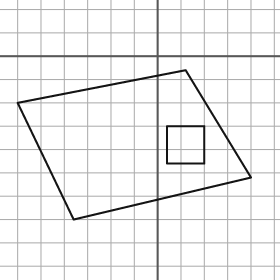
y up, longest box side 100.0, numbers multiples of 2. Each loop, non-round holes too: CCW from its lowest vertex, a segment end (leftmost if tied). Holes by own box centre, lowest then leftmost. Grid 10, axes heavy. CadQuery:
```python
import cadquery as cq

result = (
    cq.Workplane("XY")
    .moveTo(-36.0, -70.0)
    .lineTo(40.0, -52.0)
    .lineTo(12.0, -6.0)
    .lineTo(-60.0, -20.0)
    .close()
    .moveTo(4.0, -46.0)
    .lineTo(20.0, -46.0)
    .lineTo(20.0, -30.0)
    .lineTo(4.0, -30.0)
    .close()
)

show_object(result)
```